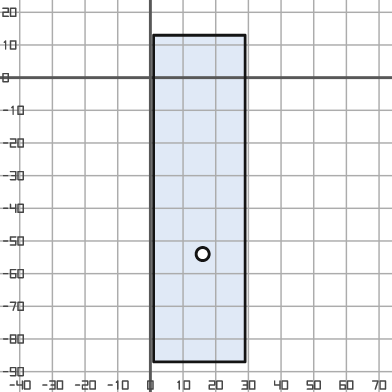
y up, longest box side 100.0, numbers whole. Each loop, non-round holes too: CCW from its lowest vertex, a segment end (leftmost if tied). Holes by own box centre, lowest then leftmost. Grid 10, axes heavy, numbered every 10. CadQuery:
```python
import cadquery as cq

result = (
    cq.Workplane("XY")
    .moveTo(1.0, -87.0)
    .lineTo(29.0, -87.0)
    .lineTo(29.0, 13.0)
    .lineTo(1.0, 13.0)
    .close()
    .moveTo(16.0, -54.0)
    .circle(2.0)
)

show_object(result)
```